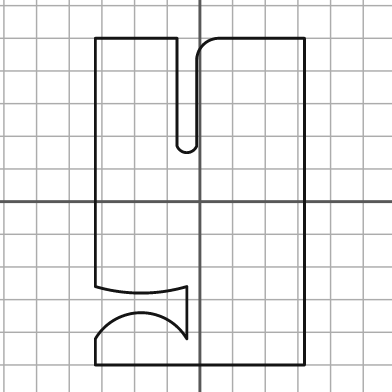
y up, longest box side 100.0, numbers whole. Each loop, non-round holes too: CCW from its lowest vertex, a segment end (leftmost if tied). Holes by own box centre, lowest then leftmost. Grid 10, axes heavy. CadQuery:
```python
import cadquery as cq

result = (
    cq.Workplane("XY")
    .moveTo(-32.0, -50.0)
    .lineTo(32.0, -50.0)
    .lineTo(32.0, 50.0)
    .lineTo(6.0, 50.0)
    .threePointArc((1.0, 48.0), (-1.0, 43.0))
    .lineTo(-1.0, 17.0)
    .threePointArc((-4.0, 15.0), (-7.0, 17.0))
    .lineTo(-7.0, 50.0)
    .lineTo(-32.0, 50.0)
    .lineTo(-32.0, -26.0)
    .threePointArc((-18.0, -28.0), (-4.0, -26.0))
    .lineTo(-4.0, -42.0)
    .threePointArc((-18.0, -34.0), (-32.0, -42.0))
    .close()
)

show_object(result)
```